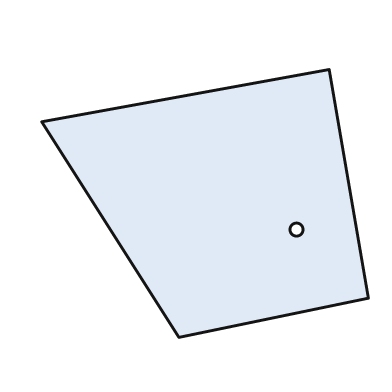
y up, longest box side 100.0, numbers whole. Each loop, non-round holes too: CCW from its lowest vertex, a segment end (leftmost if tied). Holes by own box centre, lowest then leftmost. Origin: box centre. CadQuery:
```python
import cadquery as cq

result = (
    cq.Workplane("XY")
    .moveTo(-8.0, -41.0)
    .lineTo(50.0, -29.0)
    .lineTo(38.0, 41.0)
    .lineTo(-50.0, 25.0)
    .close()
    .moveTo(28.0, -8.0)
    .circle(2.0)
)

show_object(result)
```